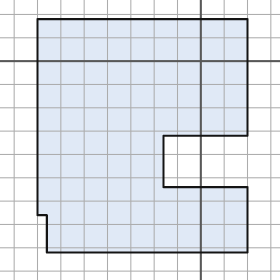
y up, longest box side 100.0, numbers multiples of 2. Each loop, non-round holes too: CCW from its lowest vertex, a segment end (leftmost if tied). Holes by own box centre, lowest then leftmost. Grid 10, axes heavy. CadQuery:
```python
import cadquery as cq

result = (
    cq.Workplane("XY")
    .moveTo(-66.0, -82.0)
    .lineTo(20.0, -82.0)
    .lineTo(20.0, -54.0)
    .lineTo(-16.0, -54.0)
    .lineTo(-16.0, -32.0)
    .lineTo(20.0, -32.0)
    .lineTo(20.0, 18.0)
    .lineTo(-70.0, 18.0)
    .lineTo(-70.0, -66.0)
    .lineTo(-66.0, -66.0)
    .close()
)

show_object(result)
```